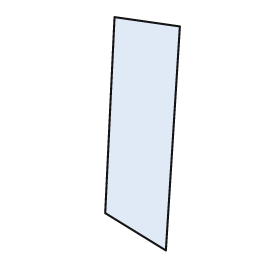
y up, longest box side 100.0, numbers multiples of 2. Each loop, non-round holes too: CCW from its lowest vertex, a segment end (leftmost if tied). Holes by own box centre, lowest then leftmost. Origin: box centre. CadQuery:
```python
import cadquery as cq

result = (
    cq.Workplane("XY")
    .moveTo(10.0, -50.0)
    .lineTo(16.0, 46.0)
    .lineTo(-12.0, 50.0)
    .lineTo(-16.0, -34.0)
    .close()
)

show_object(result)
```